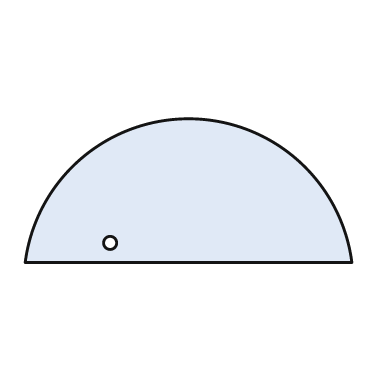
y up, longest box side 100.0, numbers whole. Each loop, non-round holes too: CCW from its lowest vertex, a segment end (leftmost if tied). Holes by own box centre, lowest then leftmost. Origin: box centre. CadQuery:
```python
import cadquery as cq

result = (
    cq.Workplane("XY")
    .moveTo(-50.0, -22.0)
    .lineTo(50.0, -22.0)
    .threePointArc((0.0, 22.0), (-50.0, -22.0))
    .close()
    .moveTo(-24.0, -16.0)
    .circle(2.0)
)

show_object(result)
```